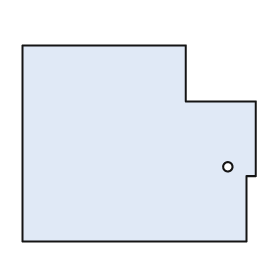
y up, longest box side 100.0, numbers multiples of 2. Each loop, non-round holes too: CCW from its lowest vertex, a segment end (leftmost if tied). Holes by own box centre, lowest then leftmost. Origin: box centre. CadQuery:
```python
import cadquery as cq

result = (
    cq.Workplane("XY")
    .moveTo(-50.0, -42.0)
    .lineTo(46.0, -42.0)
    .lineTo(46.0, -14.0)
    .lineTo(50.0, -14.0)
    .lineTo(50.0, 18.0)
    .lineTo(20.0, 18.0)
    .lineTo(20.0, 42.0)
    .lineTo(-50.0, 42.0)
    .close()
    .moveTo(38.0, -10.0)
    .circle(2.0)
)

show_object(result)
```